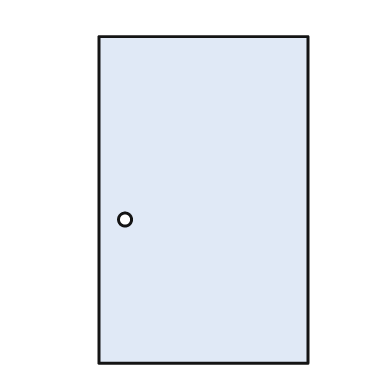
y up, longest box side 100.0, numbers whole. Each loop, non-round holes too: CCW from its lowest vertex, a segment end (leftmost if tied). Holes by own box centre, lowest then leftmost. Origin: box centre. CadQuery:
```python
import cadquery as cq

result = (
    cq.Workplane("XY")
    .moveTo(-32.0, -50.0)
    .lineTo(32.0, -50.0)
    .lineTo(32.0, 50.0)
    .lineTo(-32.0, 50.0)
    .close()
    .moveTo(-24.0, -6.0)
    .circle(2.0)
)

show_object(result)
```